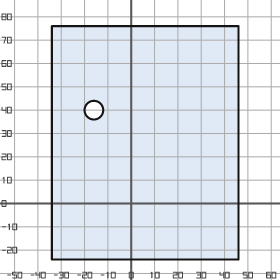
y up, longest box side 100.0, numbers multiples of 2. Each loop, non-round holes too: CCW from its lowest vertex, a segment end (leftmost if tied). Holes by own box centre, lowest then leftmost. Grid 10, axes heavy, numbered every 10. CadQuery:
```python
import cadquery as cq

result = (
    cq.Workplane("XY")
    .moveTo(-34.0, -24.0)
    .lineTo(46.0, -24.0)
    .lineTo(46.0, 76.0)
    .lineTo(-34.0, 76.0)
    .close()
    .moveTo(-16.0, 40.0)
    .circle(4.0)
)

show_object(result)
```